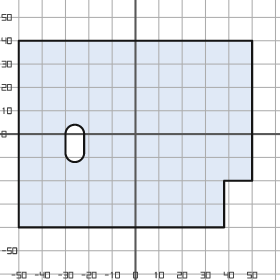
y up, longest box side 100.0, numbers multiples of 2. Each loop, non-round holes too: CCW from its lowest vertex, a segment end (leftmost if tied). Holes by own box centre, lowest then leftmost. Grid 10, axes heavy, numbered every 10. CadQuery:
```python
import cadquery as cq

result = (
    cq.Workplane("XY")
    .moveTo(-50.0, -40.0)
    .lineTo(38.0, -40.0)
    .lineTo(38.0, -20.0)
    .lineTo(50.0, -20.0)
    .lineTo(50.0, 40.0)
    .lineTo(-50.0, 40.0)
    .close()
    .moveTo(-30.0, -8.0)
    .threePointArc((-26.0, -12.0), (-22.0, -8.0))
    .lineTo(-22.0, 0.0)
    .threePointArc((-26.0, 4.0), (-30.0, 0.0))
    .close()
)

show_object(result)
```